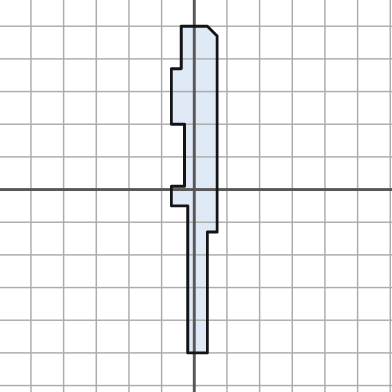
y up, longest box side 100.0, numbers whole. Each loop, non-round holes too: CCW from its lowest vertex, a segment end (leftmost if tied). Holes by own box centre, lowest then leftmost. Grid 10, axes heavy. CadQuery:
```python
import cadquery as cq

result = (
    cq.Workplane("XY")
    .moveTo(-2.0, -50.0)
    .lineTo(4.0, -50.0)
    .lineTo(4.0, -13.0)
    .lineTo(7.0, -13.0)
    .lineTo(7.0, 47.0)
    .lineTo(4.0, 50.0)
    .lineTo(-4.0, 50.0)
    .lineTo(-4.0, 37.0)
    .lineTo(-7.0, 37.0)
    .lineTo(-7.0, 20.0)
    .lineTo(-3.0, 20.0)
    .lineTo(-3.0, 1.0)
    .lineTo(-7.0, 1.0)
    .lineTo(-7.0, -5.0)
    .lineTo(-2.0, -5.0)
    .close()
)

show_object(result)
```